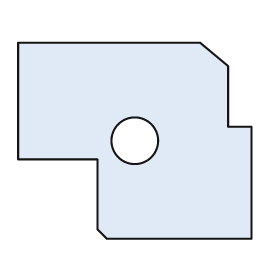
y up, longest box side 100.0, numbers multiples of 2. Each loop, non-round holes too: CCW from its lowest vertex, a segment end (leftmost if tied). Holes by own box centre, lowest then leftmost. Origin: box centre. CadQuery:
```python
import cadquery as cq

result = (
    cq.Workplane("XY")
    .moveTo(-12.0, -42.0)
    .lineTo(50.0, -42.0)
    .lineTo(50.0, 6.0)
    .lineTo(40.0, 6.0)
    .lineTo(40.0, 32.0)
    .lineTo(28.0, 42.0)
    .lineTo(-50.0, 42.0)
    .lineTo(-50.0, -8.0)
    .lineTo(-16.0, -8.0)
    .lineTo(-16.0, -38.0)
    .close()
    .moveTo(0.0, 0.0)
    .circle(10.0)
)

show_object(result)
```